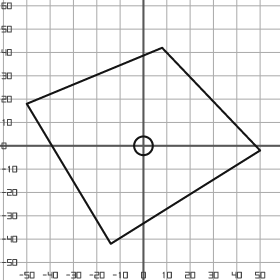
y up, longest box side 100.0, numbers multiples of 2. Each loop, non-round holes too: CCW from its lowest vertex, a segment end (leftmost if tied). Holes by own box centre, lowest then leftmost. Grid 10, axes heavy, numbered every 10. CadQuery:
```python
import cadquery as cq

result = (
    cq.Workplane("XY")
    .moveTo(-14.0, -42.0)
    .lineTo(50.0, -2.0)
    .lineTo(8.0, 42.0)
    .lineTo(-50.0, 18.0)
    .close()
    .moveTo(0.0, 0.0)
    .circle(4.0)
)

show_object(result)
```